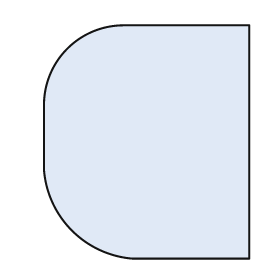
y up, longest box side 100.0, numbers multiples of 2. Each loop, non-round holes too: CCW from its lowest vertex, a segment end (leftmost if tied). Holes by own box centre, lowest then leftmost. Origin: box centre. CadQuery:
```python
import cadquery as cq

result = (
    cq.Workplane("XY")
    .moveTo(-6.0, -50.0)
    .lineTo(44.0, -50.0)
    .lineTo(44.0, 50.0)
    .lineTo(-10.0, 50.0)
    .threePointArc((-34.0, 40.0), (-44.0, 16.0))
    .lineTo(-44.0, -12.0)
    .threePointArc((-32.0, -38.0), (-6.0, -50.0))
    .close()
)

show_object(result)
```